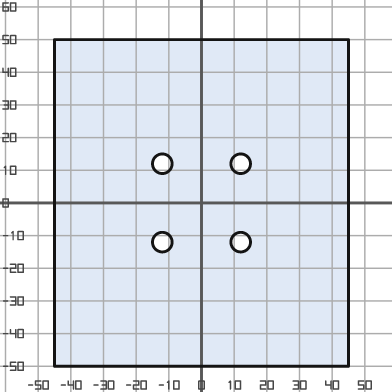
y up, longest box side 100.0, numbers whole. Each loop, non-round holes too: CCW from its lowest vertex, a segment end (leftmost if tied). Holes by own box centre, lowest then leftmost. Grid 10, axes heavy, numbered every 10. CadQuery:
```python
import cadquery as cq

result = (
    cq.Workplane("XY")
    .moveTo(-45.0, -50.0)
    .lineTo(45.0, -50.0)
    .lineTo(45.0, 50.0)
    .lineTo(-45.0, 50.0)
    .close()
    .moveTo(-12.0, -12.0)
    .circle(3.0)
    .moveTo(12.0, -12.0)
    .circle(3.0)
    .moveTo(-12.0, 12.0)
    .circle(3.0)
    .moveTo(12.0, 12.0)
    .circle(3.0)
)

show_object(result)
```